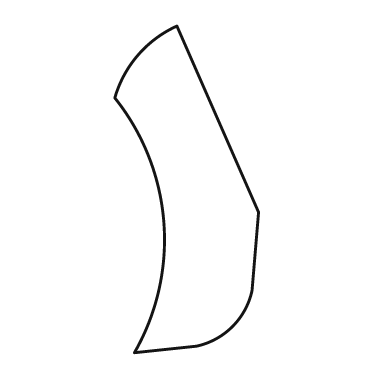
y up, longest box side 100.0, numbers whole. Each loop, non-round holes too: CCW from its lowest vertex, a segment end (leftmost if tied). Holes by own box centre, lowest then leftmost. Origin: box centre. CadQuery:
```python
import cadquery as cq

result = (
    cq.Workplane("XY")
    .moveTo(-16.0, -50.0)
    .lineTo(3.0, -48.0)
    .threePointArc((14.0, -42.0), (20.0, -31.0))
    .lineTo(22.0, -7.0)
    .lineTo(-3.0, 50.0)
    .threePointArc((-15.0, 41.0), (-22.0, 28.0))
    .threePointArc((-7.0, -10.0), (-16.0, -50.0))
    .close()
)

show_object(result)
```